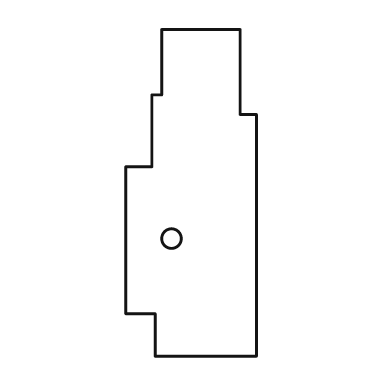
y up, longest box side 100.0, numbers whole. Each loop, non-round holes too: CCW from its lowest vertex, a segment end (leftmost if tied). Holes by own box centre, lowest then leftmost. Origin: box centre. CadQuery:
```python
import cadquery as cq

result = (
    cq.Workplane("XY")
    .moveTo(-11.0, -50.0)
    .lineTo(20.0, -50.0)
    .lineTo(20.0, 24.0)
    .lineTo(15.0, 24.0)
    .lineTo(15.0, 50.0)
    .lineTo(-9.0, 50.0)
    .lineTo(-9.0, 30.0)
    .lineTo(-12.0, 30.0)
    .lineTo(-12.0, 8.0)
    .lineTo(-20.0, 8.0)
    .lineTo(-20.0, -37.0)
    .lineTo(-11.0, -37.0)
    .close()
    .moveTo(-6.0, -14.0)
    .circle(3.0)
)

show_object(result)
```